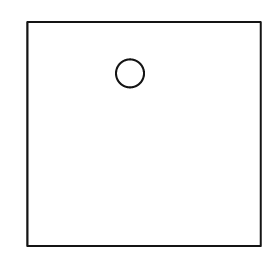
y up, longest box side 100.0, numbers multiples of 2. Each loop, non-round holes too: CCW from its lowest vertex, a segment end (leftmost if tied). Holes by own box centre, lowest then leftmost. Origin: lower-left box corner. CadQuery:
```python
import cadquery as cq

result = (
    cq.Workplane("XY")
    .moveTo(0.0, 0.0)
    .lineTo(100.0, 0.0)
    .lineTo(100.0, 96.0)
    .lineTo(0.0, 96.0)
    .close()
    .moveTo(44.0, 74.0)
    .circle(6.0)
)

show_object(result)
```